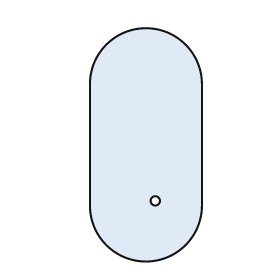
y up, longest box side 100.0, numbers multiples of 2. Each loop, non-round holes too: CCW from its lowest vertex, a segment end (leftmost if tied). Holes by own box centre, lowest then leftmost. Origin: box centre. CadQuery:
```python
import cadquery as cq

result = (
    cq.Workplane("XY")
    .moveTo(-24.0, -26.0)
    .threePointArc((0.0, -50.0), (24.0, -26.0))
    .lineTo(24.0, 26.0)
    .threePointArc((0.0, 50.0), (-24.0, 26.0))
    .close()
    .moveTo(4.0, -24.0)
    .circle(2.0)
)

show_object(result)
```